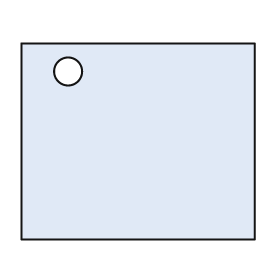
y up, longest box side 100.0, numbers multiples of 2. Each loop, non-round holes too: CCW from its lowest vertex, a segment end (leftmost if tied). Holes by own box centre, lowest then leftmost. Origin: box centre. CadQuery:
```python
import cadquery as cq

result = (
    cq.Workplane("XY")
    .moveTo(-50.0, -42.0)
    .lineTo(50.0, -42.0)
    .lineTo(50.0, 42.0)
    .lineTo(-50.0, 42.0)
    .close()
    .moveTo(-30.0, 30.0)
    .circle(6.0)
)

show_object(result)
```